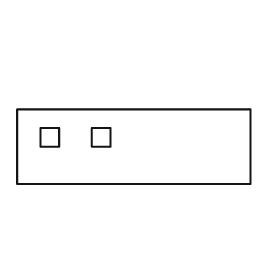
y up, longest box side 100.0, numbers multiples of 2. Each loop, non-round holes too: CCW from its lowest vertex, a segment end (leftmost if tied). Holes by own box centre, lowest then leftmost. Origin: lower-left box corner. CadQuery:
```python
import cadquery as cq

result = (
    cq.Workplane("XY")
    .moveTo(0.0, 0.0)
    .lineTo(100.0, 0.0)
    .lineTo(100.0, 32.0)
    .lineTo(0.0, 32.0)
    .close()
    .moveTo(10.0, 16.0)
    .lineTo(18.0, 16.0)
    .lineTo(18.0, 24.0)
    .lineTo(10.0, 24.0)
    .close()
    .moveTo(32.0, 16.0)
    .lineTo(40.0, 16.0)
    .lineTo(40.0, 24.0)
    .lineTo(32.0, 24.0)
    .close()
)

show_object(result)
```